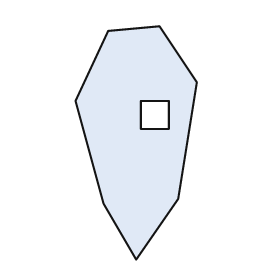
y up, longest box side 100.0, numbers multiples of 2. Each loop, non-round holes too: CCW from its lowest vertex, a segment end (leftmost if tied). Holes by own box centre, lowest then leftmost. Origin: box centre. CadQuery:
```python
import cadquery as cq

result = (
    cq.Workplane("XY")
    .moveTo(0.0, -50.0)
    .lineTo(18.0, -24.0)
    .lineTo(26.0, 26.0)
    .lineTo(10.0, 50.0)
    .lineTo(-12.0, 48.0)
    .lineTo(-26.0, 18.0)
    .lineTo(-14.0, -26.0)
    .close()
    .moveTo(2.0, 6.0)
    .lineTo(14.0, 6.0)
    .lineTo(14.0, 18.0)
    .lineTo(2.0, 18.0)
    .close()
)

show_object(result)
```